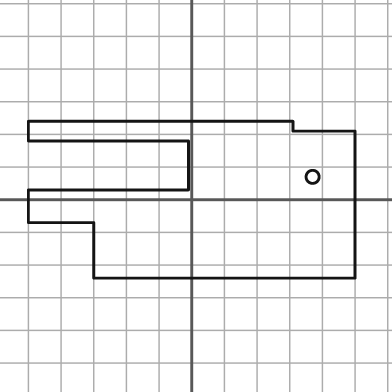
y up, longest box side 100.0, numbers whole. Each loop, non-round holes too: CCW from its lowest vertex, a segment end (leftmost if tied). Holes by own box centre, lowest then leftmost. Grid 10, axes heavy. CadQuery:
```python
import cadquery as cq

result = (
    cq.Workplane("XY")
    .moveTo(-30.0, -24.0)
    .lineTo(50.0, -24.0)
    .lineTo(50.0, 21.0)
    .lineTo(31.0, 21.0)
    .lineTo(31.0, 24.0)
    .lineTo(-50.0, 24.0)
    .lineTo(-50.0, 18.0)
    .lineTo(-1.0, 18.0)
    .lineTo(-1.0, 3.0)
    .lineTo(-50.0, 3.0)
    .lineTo(-50.0, -7.0)
    .lineTo(-30.0, -7.0)
    .close()
    .moveTo(37.0, 7.0)
    .circle(2.0)
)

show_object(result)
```